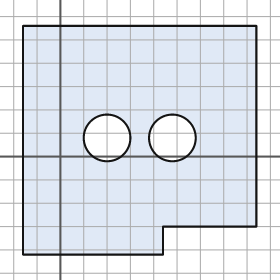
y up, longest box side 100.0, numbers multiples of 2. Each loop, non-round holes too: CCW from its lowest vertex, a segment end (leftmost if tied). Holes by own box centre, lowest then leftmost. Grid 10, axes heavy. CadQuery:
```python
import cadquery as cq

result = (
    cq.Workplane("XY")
    .moveTo(-16.0, -42.0)
    .lineTo(44.0, -42.0)
    .lineTo(44.0, -30.0)
    .lineTo(84.0, -30.0)
    .lineTo(84.0, 56.0)
    .lineTo(-16.0, 56.0)
    .close()
    .moveTo(20.0, 8.0)
    .circle(10.0)
    .moveTo(48.0, 8.0)
    .circle(10.0)
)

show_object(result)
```